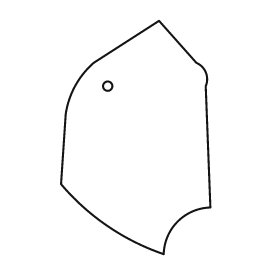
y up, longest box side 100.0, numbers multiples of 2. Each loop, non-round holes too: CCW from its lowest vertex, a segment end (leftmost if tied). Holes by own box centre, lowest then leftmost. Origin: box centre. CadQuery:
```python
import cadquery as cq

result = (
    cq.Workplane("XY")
    .moveTo(12.0, -50.0)
    .threePointArc((18.0, -36.0), (32.0, -30.0))
    .lineTo(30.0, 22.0)
    .threePointArc((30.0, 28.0), (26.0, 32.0))
    .lineTo(10.0, 50.0)
    .lineTo(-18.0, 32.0)
    .threePointArc((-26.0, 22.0), (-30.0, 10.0))
    .lineTo(-32.0, -20.0)
    .threePointArc((-12.0, -38.0), (12.0, -50.0))
    .close()
    .moveTo(-12.0, 22.0)
    .circle(2.0)
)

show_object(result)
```